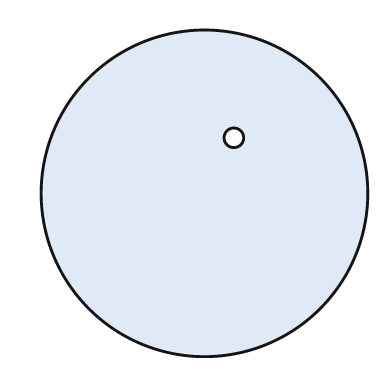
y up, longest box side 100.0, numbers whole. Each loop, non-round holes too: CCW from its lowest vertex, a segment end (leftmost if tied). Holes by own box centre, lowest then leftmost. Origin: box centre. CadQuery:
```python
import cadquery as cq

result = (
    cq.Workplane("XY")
    .moveTo(0.0, 0.0)
    .circle(50.0)
    .moveTo(9.0, 17.0)
    .circle(3.0)
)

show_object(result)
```